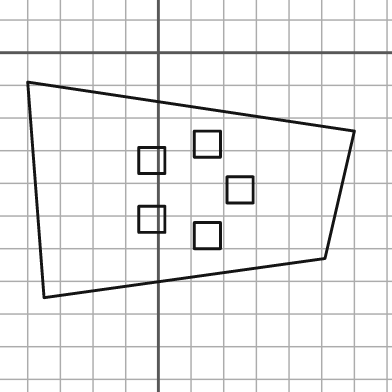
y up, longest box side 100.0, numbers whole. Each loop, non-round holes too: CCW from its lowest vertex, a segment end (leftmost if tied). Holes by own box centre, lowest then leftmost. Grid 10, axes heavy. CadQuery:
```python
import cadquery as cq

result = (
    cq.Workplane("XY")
    .moveTo(-35.0, -75.0)
    .lineTo(51.0, -63.0)
    .lineTo(60.0, -24.0)
    .lineTo(-40.0, -9.0)
    .close()
    .moveTo(11.0, -60.0)
    .lineTo(19.0, -60.0)
    .lineTo(19.0, -52.0)
    .lineTo(11.0, -52.0)
    .close()
    .moveTo(-6.0, -55.0)
    .lineTo(2.0, -55.0)
    .lineTo(2.0, -47.0)
    .lineTo(-6.0, -47.0)
    .close()
    .moveTo(21.0, -46.0)
    .lineTo(29.0, -46.0)
    .lineTo(29.0, -38.0)
    .lineTo(21.0, -38.0)
    .close()
    .moveTo(-6.0, -37.0)
    .lineTo(2.0, -37.0)
    .lineTo(2.0, -29.0)
    .lineTo(-6.0, -29.0)
    .close()
    .moveTo(11.0, -32.0)
    .lineTo(19.0, -32.0)
    .lineTo(19.0, -24.0)
    .lineTo(11.0, -24.0)
    .close()
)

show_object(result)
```